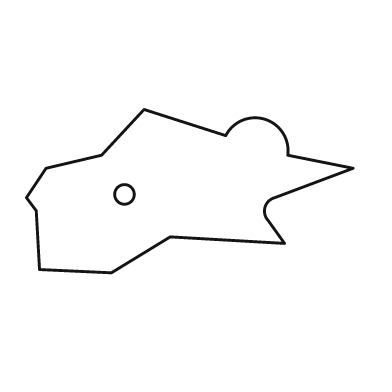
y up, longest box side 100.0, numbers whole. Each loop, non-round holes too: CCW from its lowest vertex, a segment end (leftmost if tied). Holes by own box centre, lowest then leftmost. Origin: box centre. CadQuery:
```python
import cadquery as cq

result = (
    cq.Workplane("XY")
    .moveTo(-24.0, -25.0)
    .lineTo(-6.0, -14.0)
    .lineTo(29.0, -16.0)
    .lineTo(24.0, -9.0)
    .threePointArc((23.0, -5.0), (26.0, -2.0))
    .lineTo(50.0, 7.0)
    .lineTo(30.0, 11.0)
    .threePointArc((23.0, 22.0), (11.0, 17.0))
    .lineTo(-14.0, 25.0)
    .lineTo(-27.0, 11.0)
    .lineTo(-44.0, 7.0)
    .lineTo(-50.0, -2.0)
    .lineTo(-47.0, -6.0)
    .lineTo(-46.0, -24.0)
    .close()
    .moveTo(-20.0, -1.0)
    .circle(3.0)
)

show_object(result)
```